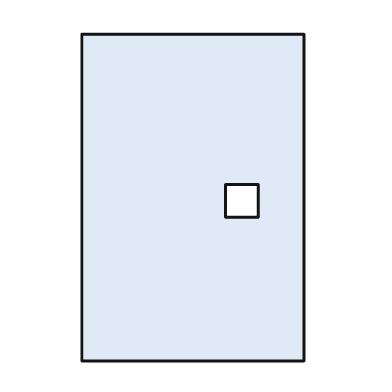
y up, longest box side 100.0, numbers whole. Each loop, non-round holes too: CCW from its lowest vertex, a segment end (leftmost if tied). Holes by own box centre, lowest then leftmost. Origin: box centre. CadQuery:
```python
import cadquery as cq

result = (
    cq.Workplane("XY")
    .moveTo(-34.0, -50.0)
    .lineTo(34.0, -50.0)
    .lineTo(34.0, 50.0)
    .lineTo(-34.0, 50.0)
    .close()
    .moveTo(10.0, -6.0)
    .lineTo(20.0, -6.0)
    .lineTo(20.0, 4.0)
    .lineTo(10.0, 4.0)
    .close()
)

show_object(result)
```